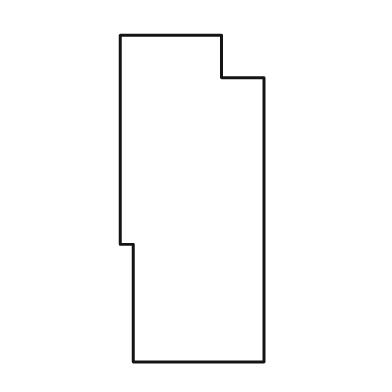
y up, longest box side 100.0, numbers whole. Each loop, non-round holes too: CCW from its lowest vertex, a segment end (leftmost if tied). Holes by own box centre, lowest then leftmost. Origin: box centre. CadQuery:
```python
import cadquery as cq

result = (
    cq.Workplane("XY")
    .moveTo(-18.0, -50.0)
    .lineTo(22.0, -50.0)
    .lineTo(22.0, 37.0)
    .lineTo(9.0, 37.0)
    .lineTo(9.0, 50.0)
    .lineTo(-22.0, 50.0)
    .lineTo(-22.0, -14.0)
    .lineTo(-18.0, -14.0)
    .close()
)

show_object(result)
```